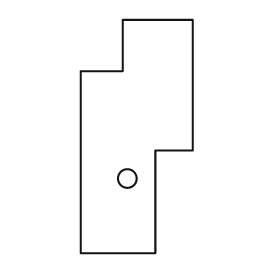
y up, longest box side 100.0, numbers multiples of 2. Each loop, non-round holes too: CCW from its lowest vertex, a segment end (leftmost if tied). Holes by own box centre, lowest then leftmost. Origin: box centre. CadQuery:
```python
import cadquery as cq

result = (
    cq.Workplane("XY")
    .moveTo(-24.0, -50.0)
    .lineTo(8.0, -50.0)
    .lineTo(8.0, -6.0)
    .lineTo(24.0, -6.0)
    .lineTo(24.0, 50.0)
    .lineTo(-6.0, 50.0)
    .lineTo(-6.0, 28.0)
    .lineTo(-24.0, 28.0)
    .close()
    .moveTo(-4.0, -18.0)
    .circle(4.0)
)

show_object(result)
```